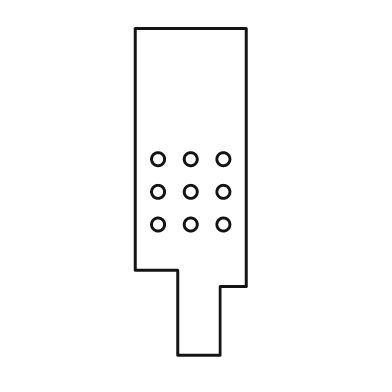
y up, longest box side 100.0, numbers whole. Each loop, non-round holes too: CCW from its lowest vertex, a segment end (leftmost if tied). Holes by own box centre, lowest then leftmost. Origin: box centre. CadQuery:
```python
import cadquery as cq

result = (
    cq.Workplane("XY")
    .moveTo(-4.0, -50.0)
    .lineTo(9.0, -50.0)
    .lineTo(9.0, -29.0)
    .lineTo(17.0, -29.0)
    .lineTo(17.0, 50.0)
    .lineTo(-17.0, 50.0)
    .lineTo(-17.0, -24.0)
    .lineTo(-4.0, -24.0)
    .close()
    .moveTo(-10.0, -10.0)
    .circle(2.0)
    .moveTo(0.0, -10.0)
    .circle(2.0)
    .moveTo(10.0, -10.0)
    .circle(2.0)
    .moveTo(-10.0, 0.0)
    .circle(2.0)
    .moveTo(0.0, 0.0)
    .circle(2.0)
    .moveTo(10.0, 0.0)
    .circle(2.0)
    .moveTo(-10.0, 10.0)
    .circle(2.0)
    .moveTo(0.0, 10.0)
    .circle(2.0)
    .moveTo(10.0, 10.0)
    .circle(2.0)
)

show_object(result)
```